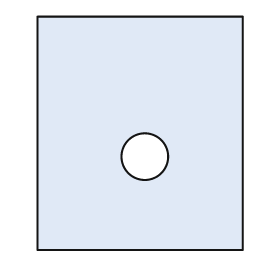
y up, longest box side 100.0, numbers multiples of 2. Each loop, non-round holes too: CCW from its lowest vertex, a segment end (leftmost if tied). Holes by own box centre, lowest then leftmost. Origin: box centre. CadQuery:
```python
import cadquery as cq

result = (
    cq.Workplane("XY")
    .moveTo(-44.0, -50.0)
    .lineTo(44.0, -50.0)
    .lineTo(44.0, 50.0)
    .lineTo(-44.0, 50.0)
    .close()
    .moveTo(2.0, -10.0)
    .circle(10.0)
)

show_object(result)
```